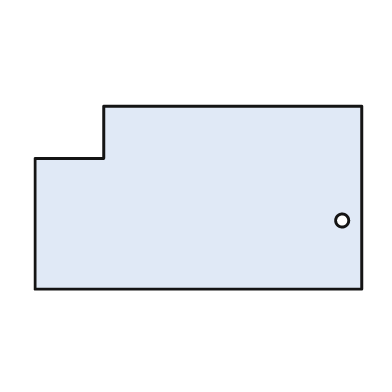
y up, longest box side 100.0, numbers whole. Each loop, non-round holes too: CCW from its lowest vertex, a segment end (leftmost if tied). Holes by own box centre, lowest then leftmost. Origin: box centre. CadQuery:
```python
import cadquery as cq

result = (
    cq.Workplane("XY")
    .moveTo(-50.0, -28.0)
    .lineTo(50.0, -28.0)
    .lineTo(50.0, 28.0)
    .lineTo(-29.0, 28.0)
    .lineTo(-29.0, 12.0)
    .lineTo(-50.0, 12.0)
    .close()
    .moveTo(44.0, -7.0)
    .circle(2.0)
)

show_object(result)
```